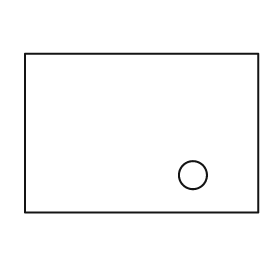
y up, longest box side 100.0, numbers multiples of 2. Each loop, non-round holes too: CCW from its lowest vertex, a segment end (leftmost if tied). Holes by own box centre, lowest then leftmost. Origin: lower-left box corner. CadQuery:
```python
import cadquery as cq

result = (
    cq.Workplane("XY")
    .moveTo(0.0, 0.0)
    .lineTo(100.0, 0.0)
    .lineTo(100.0, 68.0)
    .lineTo(0.0, 68.0)
    .close()
    .moveTo(72.0, 16.0)
    .circle(6.0)
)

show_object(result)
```